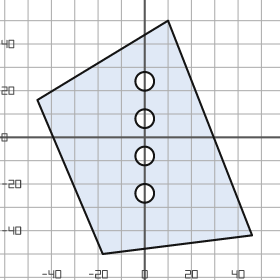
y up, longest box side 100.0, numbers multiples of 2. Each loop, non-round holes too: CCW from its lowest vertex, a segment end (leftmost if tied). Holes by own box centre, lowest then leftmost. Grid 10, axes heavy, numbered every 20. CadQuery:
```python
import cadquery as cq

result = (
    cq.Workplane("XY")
    .moveTo(-18.0, -50.0)
    .lineTo(46.0, -42.0)
    .lineTo(10.0, 50.0)
    .lineTo(-46.0, 16.0)
    .close()
    .moveTo(0.0, -24.0)
    .circle(4.0)
    .moveTo(0.0, -8.0)
    .circle(4.0)
    .moveTo(0.0, 8.0)
    .circle(4.0)
    .moveTo(0.0, 24.0)
    .circle(4.0)
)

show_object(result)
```